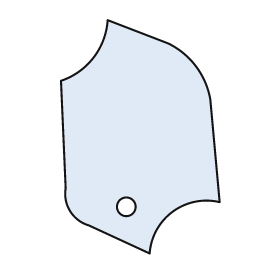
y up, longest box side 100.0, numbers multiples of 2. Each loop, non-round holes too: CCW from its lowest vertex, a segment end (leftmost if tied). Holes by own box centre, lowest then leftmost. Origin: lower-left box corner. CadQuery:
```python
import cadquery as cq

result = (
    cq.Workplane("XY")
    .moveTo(38.0, 0.0)
    .threePointArc((48.0, 18.0), (68.0, 22.0))
    .lineTo(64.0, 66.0)
    .threePointArc((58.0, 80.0), (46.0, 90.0))
    .lineTo(20.0, 100.0)
    .threePointArc((14.0, 84.0), (0.0, 74.0))
    .lineTo(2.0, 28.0)
    .threePointArc((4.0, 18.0), (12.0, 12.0))
    .close()
    .moveTo(28.0, 20.0)
    .circle(4.0)
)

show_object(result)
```